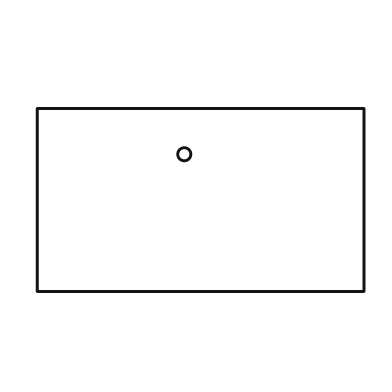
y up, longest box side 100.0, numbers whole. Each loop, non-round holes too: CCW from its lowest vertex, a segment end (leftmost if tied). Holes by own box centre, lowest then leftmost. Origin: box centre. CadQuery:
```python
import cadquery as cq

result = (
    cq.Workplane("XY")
    .moveTo(-50.0, -28.0)
    .lineTo(50.0, -28.0)
    .lineTo(50.0, 28.0)
    .lineTo(-50.0, 28.0)
    .close()
    .moveTo(-5.0, 14.0)
    .circle(2.0)
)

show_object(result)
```